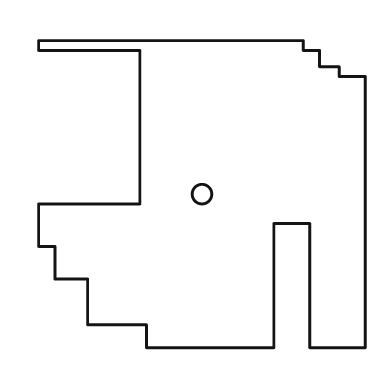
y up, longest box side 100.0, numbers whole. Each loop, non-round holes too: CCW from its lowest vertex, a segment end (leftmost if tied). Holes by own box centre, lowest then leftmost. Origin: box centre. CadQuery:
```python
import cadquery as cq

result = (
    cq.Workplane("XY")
    .moveTo(-17.0, -47.0)
    .lineTo(22.0, -47.0)
    .lineTo(22.0, -9.0)
    .lineTo(33.0, -9.0)
    .lineTo(33.0, -47.0)
    .lineTo(50.0, -47.0)
    .lineTo(50.0, 36.0)
    .lineTo(42.0, 36.0)
    .lineTo(42.0, 39.0)
    .lineTo(36.0, 39.0)
    .lineTo(36.0, 44.0)
    .lineTo(31.0, 44.0)
    .lineTo(31.0, 47.0)
    .lineTo(-50.0, 47.0)
    .lineTo(-50.0, 44.0)
    .lineTo(-19.0, 44.0)
    .lineTo(-19.0, -3.0)
    .lineTo(-50.0, -3.0)
    .lineTo(-50.0, -16.0)
    .lineTo(-45.0, -16.0)
    .lineTo(-45.0, -26.0)
    .lineTo(-35.0, -26.0)
    .lineTo(-35.0, -40.0)
    .lineTo(-17.0, -40.0)
    .close()
    .moveTo(0.0, 0.0)
    .circle(3.0)
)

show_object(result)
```